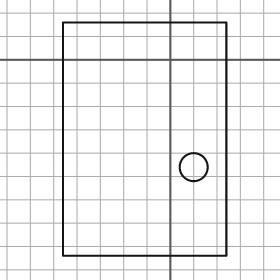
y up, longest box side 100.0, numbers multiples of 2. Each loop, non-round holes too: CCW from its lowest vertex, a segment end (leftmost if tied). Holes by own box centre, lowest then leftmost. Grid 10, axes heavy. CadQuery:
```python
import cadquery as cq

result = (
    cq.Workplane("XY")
    .moveTo(-46.0, -84.0)
    .lineTo(24.0, -84.0)
    .lineTo(24.0, 16.0)
    .lineTo(-46.0, 16.0)
    .close()
    .moveTo(10.0, -46.0)
    .circle(6.0)
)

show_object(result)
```